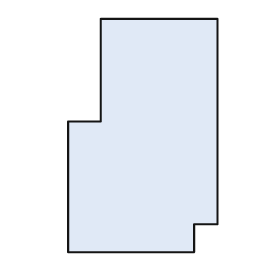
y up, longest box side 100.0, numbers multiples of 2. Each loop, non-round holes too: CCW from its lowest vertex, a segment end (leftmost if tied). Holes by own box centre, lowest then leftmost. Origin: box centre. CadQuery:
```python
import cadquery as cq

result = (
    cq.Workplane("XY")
    .moveTo(-32.0, -50.0)
    .lineTo(22.0, -50.0)
    .lineTo(22.0, -38.0)
    .lineTo(32.0, -38.0)
    .lineTo(32.0, 50.0)
    .lineTo(-18.0, 50.0)
    .lineTo(-18.0, 6.0)
    .lineTo(-32.0, 6.0)
    .close()
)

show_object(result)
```